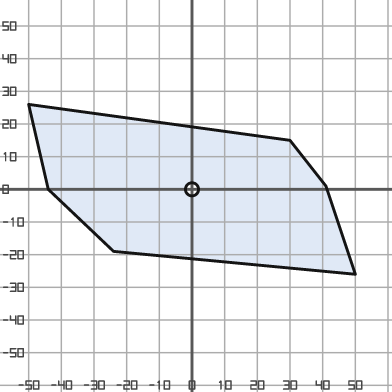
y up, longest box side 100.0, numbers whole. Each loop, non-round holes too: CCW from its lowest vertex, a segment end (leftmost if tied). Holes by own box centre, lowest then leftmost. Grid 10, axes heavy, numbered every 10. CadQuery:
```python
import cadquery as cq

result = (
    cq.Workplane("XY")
    .moveTo(50.0, -26.0)
    .lineTo(41.0, 1.0)
    .lineTo(30.0, 15.0)
    .lineTo(-50.0, 26.0)
    .lineTo(-44.0, 0.0)
    .lineTo(-24.0, -19.0)
    .close()
    .moveTo(0.0, 0.0)
    .circle(2.0)
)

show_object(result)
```